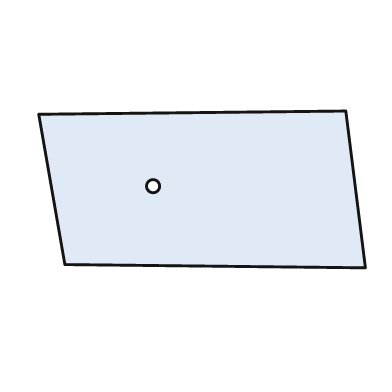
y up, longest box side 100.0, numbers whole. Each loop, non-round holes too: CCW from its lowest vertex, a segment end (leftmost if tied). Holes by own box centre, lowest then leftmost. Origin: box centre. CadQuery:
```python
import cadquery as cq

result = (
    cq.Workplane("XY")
    .moveTo(50.0, -24.0)
    .lineTo(44.0, 24.0)
    .lineTo(-50.0, 23.0)
    .lineTo(-42.0, -23.0)
    .close()
    .moveTo(-15.0, 1.0)
    .circle(2.0)
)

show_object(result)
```